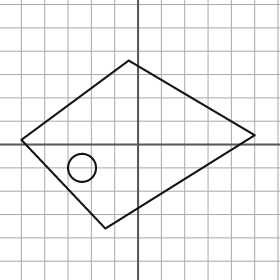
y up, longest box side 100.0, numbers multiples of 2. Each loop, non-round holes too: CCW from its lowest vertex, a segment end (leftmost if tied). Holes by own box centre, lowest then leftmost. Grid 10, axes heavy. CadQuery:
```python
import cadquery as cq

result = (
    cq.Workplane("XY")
    .moveTo(-14.0, -36.0)
    .lineTo(50.0, 4.0)
    .lineTo(-4.0, 36.0)
    .lineTo(-50.0, 2.0)
    .close()
    .moveTo(-24.0, -10.0)
    .circle(6.0)
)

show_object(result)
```